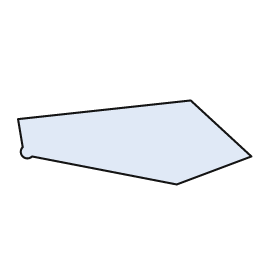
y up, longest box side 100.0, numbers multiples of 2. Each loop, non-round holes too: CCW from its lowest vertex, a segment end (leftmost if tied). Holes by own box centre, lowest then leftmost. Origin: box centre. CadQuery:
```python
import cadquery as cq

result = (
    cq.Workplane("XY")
    .moveTo(18.0, -18.0)
    .lineTo(50.0, -6.0)
    .lineTo(24.0, 18.0)
    .lineTo(-50.0, 10.0)
    .lineTo(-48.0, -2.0)
    .threePointArc((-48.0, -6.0), (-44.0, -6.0))
    .close()
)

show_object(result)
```